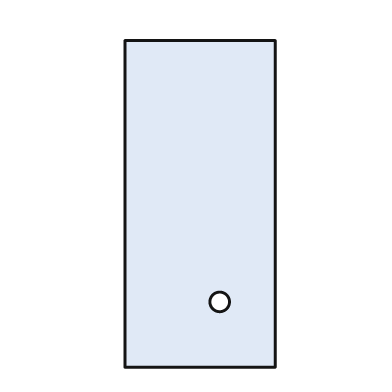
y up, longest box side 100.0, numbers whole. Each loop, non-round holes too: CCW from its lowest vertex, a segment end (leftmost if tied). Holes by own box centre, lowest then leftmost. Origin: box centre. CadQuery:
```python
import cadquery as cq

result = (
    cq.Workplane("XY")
    .moveTo(-23.0, -50.0)
    .lineTo(23.0, -50.0)
    .lineTo(23.0, 50.0)
    .lineTo(-23.0, 50.0)
    .close()
    .moveTo(6.0, -30.0)
    .circle(3.0)
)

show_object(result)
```